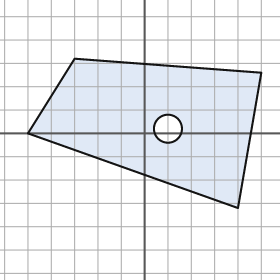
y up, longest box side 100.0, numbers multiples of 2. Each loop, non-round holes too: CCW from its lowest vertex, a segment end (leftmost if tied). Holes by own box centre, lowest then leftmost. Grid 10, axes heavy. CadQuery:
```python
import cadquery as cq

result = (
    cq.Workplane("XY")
    .moveTo(40.0, -32.0)
    .lineTo(50.0, 26.0)
    .lineTo(-30.0, 32.0)
    .lineTo(-50.0, 0.0)
    .close()
    .moveTo(10.0, 2.0)
    .circle(6.0)
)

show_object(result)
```